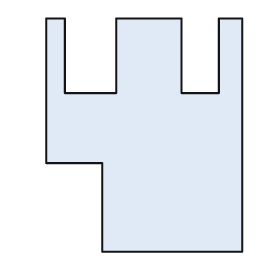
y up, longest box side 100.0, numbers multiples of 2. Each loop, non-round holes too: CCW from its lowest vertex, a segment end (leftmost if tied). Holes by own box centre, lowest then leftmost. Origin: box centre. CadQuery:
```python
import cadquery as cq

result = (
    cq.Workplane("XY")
    .moveTo(-18.0, -50.0)
    .lineTo(42.0, -50.0)
    .lineTo(42.0, 50.0)
    .lineTo(32.0, 50.0)
    .lineTo(32.0, 18.0)
    .lineTo(16.0, 18.0)
    .lineTo(16.0, 50.0)
    .lineTo(-12.0, 50.0)
    .lineTo(-12.0, 18.0)
    .lineTo(-34.0, 18.0)
    .lineTo(-34.0, 50.0)
    .lineTo(-42.0, 50.0)
    .lineTo(-42.0, -12.0)
    .lineTo(-18.0, -12.0)
    .close()
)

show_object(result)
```